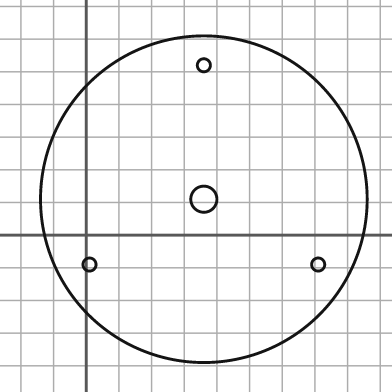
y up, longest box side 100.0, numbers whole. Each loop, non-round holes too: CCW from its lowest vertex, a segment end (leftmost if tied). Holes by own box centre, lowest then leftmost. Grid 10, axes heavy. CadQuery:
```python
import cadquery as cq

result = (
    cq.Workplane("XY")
    .moveTo(36.0, 11.0)
    .circle(50.0)
    .moveTo(1.0, -9.0)
    .circle(2.0)
    .moveTo(71.0, -9.0)
    .circle(2.0)
    .moveTo(36.0, 11.0)
    .circle(4.0)
    .moveTo(36.0, 52.0)
    .circle(2.0)
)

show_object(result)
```